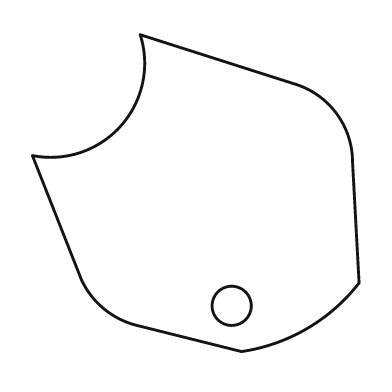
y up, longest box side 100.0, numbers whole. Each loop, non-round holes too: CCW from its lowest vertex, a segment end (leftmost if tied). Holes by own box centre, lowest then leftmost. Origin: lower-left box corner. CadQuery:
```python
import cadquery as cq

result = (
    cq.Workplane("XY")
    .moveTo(64.0, 0.0)
    .threePointArc((84.0, 7.0), (100.0, 21.0))
    .lineTo(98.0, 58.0)
    .threePointArc((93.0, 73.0), (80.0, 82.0))
    .lineTo(33.0, 97.0)
    .threePointArc((27.0, 69.0), (0.0, 60.0))
    .lineTo(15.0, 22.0)
    .threePointArc((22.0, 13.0), (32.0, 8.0))
    .close()
    .moveTo(61.0, 14.0)
    .circle(6.0)
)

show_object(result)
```